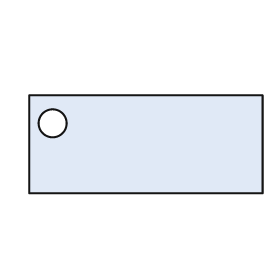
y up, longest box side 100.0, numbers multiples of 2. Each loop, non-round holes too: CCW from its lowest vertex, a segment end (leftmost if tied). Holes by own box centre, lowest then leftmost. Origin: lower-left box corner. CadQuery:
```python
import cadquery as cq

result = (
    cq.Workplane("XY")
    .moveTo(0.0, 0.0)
    .lineTo(100.0, 0.0)
    .lineTo(100.0, 42.0)
    .lineTo(0.0, 42.0)
    .close()
    .moveTo(10.0, 30.0)
    .circle(6.0)
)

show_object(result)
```